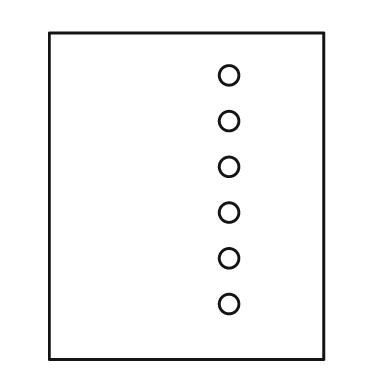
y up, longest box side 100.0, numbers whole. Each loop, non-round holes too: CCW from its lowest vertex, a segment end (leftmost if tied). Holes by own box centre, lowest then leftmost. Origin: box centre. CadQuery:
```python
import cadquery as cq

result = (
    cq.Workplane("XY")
    .moveTo(-42.0, -50.0)
    .lineTo(42.0, -50.0)
    .lineTo(42.0, 50.0)
    .lineTo(-42.0, 50.0)
    .close()
    .moveTo(13.0, -33.0)
    .circle(3.0)
    .moveTo(13.0, -19.0)
    .circle(3.0)
    .moveTo(13.0, -5.0)
    .circle(3.0)
    .moveTo(13.0, 9.0)
    .circle(3.0)
    .moveTo(13.0, 23.0)
    .circle(3.0)
    .moveTo(13.0, 37.0)
    .circle(3.0)
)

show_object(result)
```